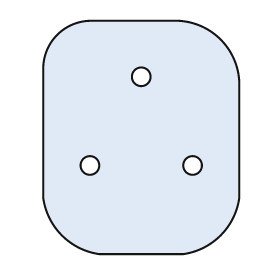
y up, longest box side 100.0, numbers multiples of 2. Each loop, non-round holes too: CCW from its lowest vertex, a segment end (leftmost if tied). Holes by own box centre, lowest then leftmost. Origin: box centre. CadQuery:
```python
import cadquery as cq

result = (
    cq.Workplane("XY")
    .moveTo(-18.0, -50.0)
    .lineTo(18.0, -50.0)
    .threePointArc((34.0, -42.0), (42.0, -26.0))
    .lineTo(42.0, 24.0)
    .threePointArc((34.0, 42.0), (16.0, 50.0))
    .lineTo(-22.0, 50.0)
    .threePointArc((-36.0, 44.0), (-42.0, 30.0))
    .lineTo(-42.0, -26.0)
    .threePointArc((-34.0, -42.0), (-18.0, -50.0))
    .close()
    .moveTo(-22.0, -12.0)
    .circle(4.0)
    .moveTo(22.0, -12.0)
    .circle(4.0)
    .moveTo(0.0, 26.0)
    .circle(4.0)
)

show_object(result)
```